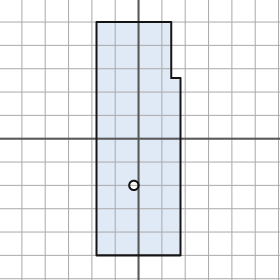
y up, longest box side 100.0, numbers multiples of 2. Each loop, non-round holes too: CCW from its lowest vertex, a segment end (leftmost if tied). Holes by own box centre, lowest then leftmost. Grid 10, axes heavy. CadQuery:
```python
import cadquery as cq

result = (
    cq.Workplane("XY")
    .moveTo(-18.0, -50.0)
    .lineTo(18.0, -50.0)
    .lineTo(18.0, 26.0)
    .lineTo(14.0, 26.0)
    .lineTo(14.0, 50.0)
    .lineTo(-18.0, 50.0)
    .close()
    .moveTo(-2.0, -20.0)
    .circle(2.0)
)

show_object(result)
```